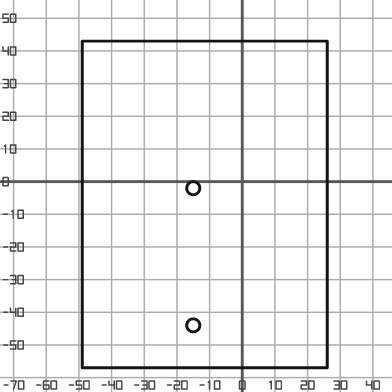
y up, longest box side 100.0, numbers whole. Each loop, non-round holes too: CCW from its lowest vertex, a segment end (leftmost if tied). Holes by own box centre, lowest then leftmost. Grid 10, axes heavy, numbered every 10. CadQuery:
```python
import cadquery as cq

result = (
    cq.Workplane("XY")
    .moveTo(-49.0, -57.0)
    .lineTo(26.0, -57.0)
    .lineTo(26.0, 43.0)
    .lineTo(-49.0, 43.0)
    .close()
    .moveTo(-15.0, -44.0)
    .circle(2.0)
    .moveTo(-15.0, -2.0)
    .circle(2.0)
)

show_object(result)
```